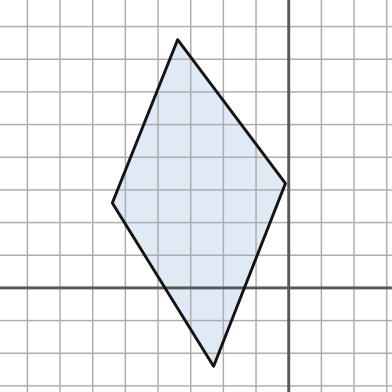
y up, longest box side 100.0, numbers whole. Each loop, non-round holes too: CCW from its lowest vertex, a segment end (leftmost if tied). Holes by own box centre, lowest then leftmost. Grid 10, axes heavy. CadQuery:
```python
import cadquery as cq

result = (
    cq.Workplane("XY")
    .moveTo(-23.0, -24.0)
    .lineTo(-1.0, 32.0)
    .lineTo(-34.0, 76.0)
    .lineTo(-54.0, 26.0)
    .close()
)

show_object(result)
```